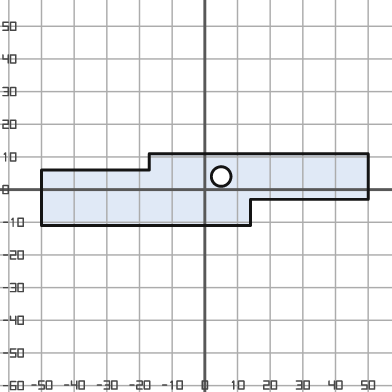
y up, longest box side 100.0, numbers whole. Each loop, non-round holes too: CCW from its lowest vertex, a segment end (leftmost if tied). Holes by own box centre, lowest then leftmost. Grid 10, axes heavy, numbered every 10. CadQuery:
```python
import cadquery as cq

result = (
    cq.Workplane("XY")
    .moveTo(-50.0, -11.0)
    .lineTo(14.0, -11.0)
    .lineTo(14.0, -3.0)
    .lineTo(50.0, -3.0)
    .lineTo(50.0, 11.0)
    .lineTo(-17.0, 11.0)
    .lineTo(-17.0, 6.0)
    .lineTo(-50.0, 6.0)
    .close()
    .moveTo(5.0, 4.0)
    .circle(3.0)
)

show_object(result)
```